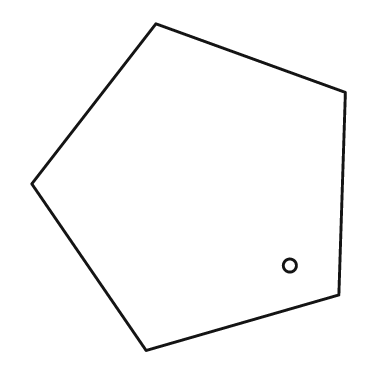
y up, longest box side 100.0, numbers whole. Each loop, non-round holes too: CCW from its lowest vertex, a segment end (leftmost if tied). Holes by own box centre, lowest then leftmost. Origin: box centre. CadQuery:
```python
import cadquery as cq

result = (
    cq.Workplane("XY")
    .moveTo(-13.0, -50.0)
    .lineTo(46.0, -33.0)
    .lineTo(48.0, 29.0)
    .lineTo(-10.0, 50.0)
    .lineTo(-48.0, 1.0)
    .close()
    .moveTo(31.0, -24.0)
    .circle(2.0)
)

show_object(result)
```